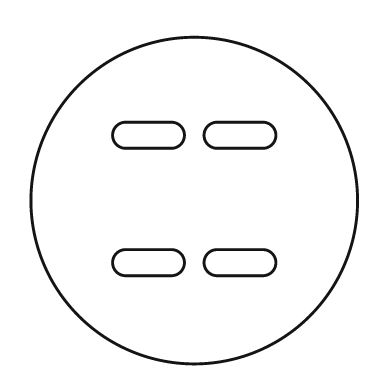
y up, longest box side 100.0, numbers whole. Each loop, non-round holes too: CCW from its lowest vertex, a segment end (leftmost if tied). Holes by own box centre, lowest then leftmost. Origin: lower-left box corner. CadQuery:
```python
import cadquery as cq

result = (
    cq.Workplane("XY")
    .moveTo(50.0, 50.0)
    .circle(50.0)
    .moveTo(29.0, 27.0)
    .lineTo(43.0, 27.0)
    .threePointArc((47.0, 31.0), (43.0, 35.0))
    .lineTo(29.0, 35.0)
    .threePointArc((25.0, 31.0), (29.0, 27.0))
    .close()
    .moveTo(57.0, 27.0)
    .lineTo(71.0, 27.0)
    .threePointArc((75.0, 31.0), (71.0, 35.0))
    .lineTo(57.0, 35.0)
    .threePointArc((53.0, 31.0), (57.0, 27.0))
    .close()
    .moveTo(29.0, 66.0)
    .lineTo(43.0, 66.0)
    .threePointArc((47.0, 70.0), (43.0, 74.0))
    .lineTo(29.0, 74.0)
    .threePointArc((25.0, 70.0), (29.0, 66.0))
    .close()
    .moveTo(57.0, 66.0)
    .lineTo(71.0, 66.0)
    .threePointArc((75.0, 70.0), (71.0, 74.0))
    .lineTo(57.0, 74.0)
    .threePointArc((53.0, 70.0), (57.0, 66.0))
    .close()
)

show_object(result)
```